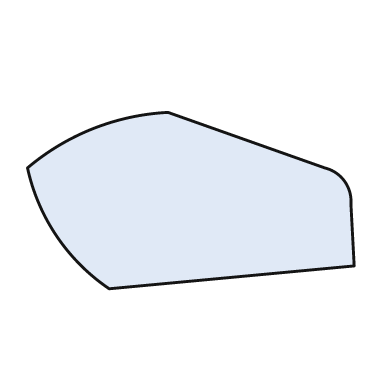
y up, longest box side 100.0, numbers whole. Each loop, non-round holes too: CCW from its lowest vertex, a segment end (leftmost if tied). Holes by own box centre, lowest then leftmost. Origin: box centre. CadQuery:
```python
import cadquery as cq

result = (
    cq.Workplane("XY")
    .moveTo(-25.0, -27.0)
    .lineTo(50.0, -20.0)
    .lineTo(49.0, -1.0)
    .threePointArc((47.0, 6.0), (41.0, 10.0))
    .lineTo(-7.0, 27.0)
    .threePointArc((-30.0, 22.0), (-50.0, 10.0))
    .threePointArc((-41.0, -11.0), (-25.0, -27.0))
    .close()
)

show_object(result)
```